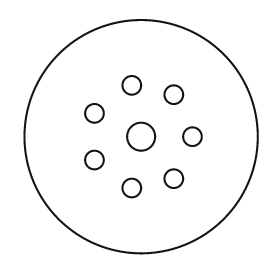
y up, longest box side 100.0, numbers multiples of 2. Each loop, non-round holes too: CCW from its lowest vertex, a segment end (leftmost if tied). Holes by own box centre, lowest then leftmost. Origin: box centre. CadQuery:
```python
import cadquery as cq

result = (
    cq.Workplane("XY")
    .moveTo(0.0, 0.0)
    .circle(50.0)
    .moveTo(-4.0, -22.0)
    .circle(4.0)
    .moveTo(14.0, -18.0)
    .circle(4.0)
    .moveTo(-20.0, -10.0)
    .circle(4.0)
    .moveTo(0.0, 0.0)
    .circle(6.0)
    .moveTo(22.0, 0.0)
    .circle(4.0)
    .moveTo(-20.0, 10.0)
    .circle(4.0)
    .moveTo(14.0, 18.0)
    .circle(4.0)
    .moveTo(-4.0, 22.0)
    .circle(4.0)
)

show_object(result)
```